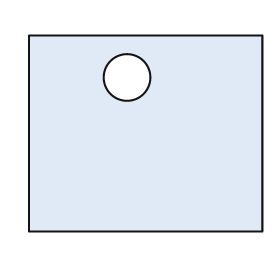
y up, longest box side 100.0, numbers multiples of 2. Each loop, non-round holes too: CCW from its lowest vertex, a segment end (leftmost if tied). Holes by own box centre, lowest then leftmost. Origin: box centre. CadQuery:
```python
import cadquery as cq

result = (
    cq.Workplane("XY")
    .moveTo(-50.0, -42.0)
    .lineTo(50.0, -42.0)
    .lineTo(50.0, 42.0)
    .lineTo(-50.0, 42.0)
    .close()
    .moveTo(-8.0, 24.0)
    .circle(10.0)
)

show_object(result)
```